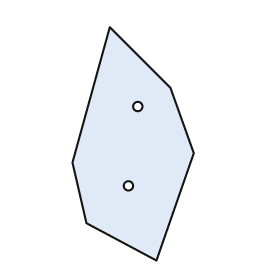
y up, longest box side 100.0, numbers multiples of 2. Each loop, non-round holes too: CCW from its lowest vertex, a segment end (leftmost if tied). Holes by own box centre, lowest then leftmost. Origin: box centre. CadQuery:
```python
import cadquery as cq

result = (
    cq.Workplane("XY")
    .moveTo(10.0, -50.0)
    .lineTo(26.0, -4.0)
    .lineTo(16.0, 24.0)
    .lineTo(-10.0, 50.0)
    .lineTo(-26.0, -8.0)
    .lineTo(-20.0, -34.0)
    .close()
    .moveTo(-2.0, -18.0)
    .circle(2.0)
    .moveTo(2.0, 16.0)
    .circle(2.0)
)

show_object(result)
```